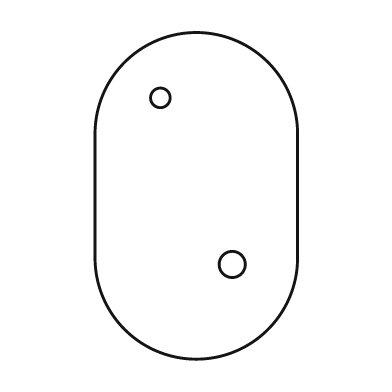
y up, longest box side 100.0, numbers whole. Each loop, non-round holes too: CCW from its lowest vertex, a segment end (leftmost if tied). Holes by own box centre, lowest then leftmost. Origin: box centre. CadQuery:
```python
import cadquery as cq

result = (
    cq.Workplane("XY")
    .moveTo(-31.0, -19.0)
    .threePointArc((0.0, -50.0), (31.0, -19.0))
    .lineTo(31.0, 19.0)
    .threePointArc((0.0, 50.0), (-31.0, 19.0))
    .close()
    .moveTo(11.0, -21.0)
    .circle(4.0)
    .moveTo(-11.0, 30.0)
    .circle(3.0)
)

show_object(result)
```